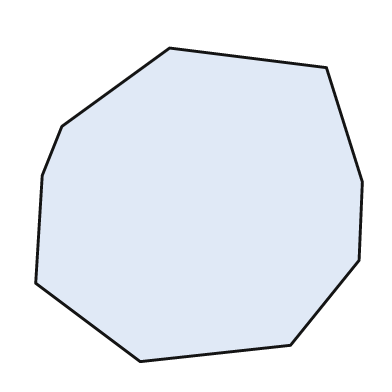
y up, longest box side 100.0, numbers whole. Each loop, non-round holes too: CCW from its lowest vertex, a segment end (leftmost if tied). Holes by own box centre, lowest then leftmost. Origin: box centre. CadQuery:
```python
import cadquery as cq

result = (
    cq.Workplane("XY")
    .moveTo(-18.0, -48.0)
    .lineTo(28.0, -43.0)
    .lineTo(49.0, -17.0)
    .lineTo(50.0, 7.0)
    .lineTo(39.0, 42.0)
    .lineTo(-9.0, 48.0)
    .lineTo(-42.0, 24.0)
    .lineTo(-48.0, 9.0)
    .lineTo(-50.0, -24.0)
    .close()
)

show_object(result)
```